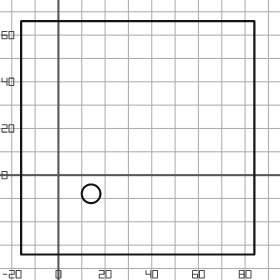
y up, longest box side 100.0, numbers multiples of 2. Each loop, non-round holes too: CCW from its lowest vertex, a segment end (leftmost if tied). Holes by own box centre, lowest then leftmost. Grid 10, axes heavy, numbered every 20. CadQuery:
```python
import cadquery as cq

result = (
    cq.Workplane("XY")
    .moveTo(-16.0, -34.0)
    .lineTo(84.0, -34.0)
    .lineTo(84.0, 66.0)
    .lineTo(-16.0, 66.0)
    .close()
    .moveTo(14.0, -8.0)
    .circle(4.0)
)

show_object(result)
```